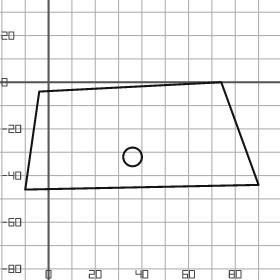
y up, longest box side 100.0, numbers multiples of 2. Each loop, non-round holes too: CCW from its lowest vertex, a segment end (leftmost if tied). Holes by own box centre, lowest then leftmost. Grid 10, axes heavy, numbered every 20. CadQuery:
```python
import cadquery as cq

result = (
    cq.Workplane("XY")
    .moveTo(-10.0, -46.0)
    .lineTo(90.0, -44.0)
    .lineTo(74.0, 0.0)
    .lineTo(-4.0, -4.0)
    .close()
    .moveTo(36.0, -32.0)
    .circle(4.0)
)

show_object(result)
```